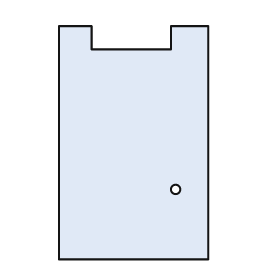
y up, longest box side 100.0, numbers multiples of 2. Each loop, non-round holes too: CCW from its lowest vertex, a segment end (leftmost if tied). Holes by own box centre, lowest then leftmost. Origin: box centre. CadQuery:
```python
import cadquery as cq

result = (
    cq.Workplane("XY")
    .moveTo(-32.0, -50.0)
    .lineTo(32.0, -50.0)
    .lineTo(32.0, 50.0)
    .lineTo(16.0, 50.0)
    .lineTo(16.0, 40.0)
    .lineTo(-18.0, 40.0)
    .lineTo(-18.0, 50.0)
    .lineTo(-32.0, 50.0)
    .close()
    .moveTo(18.0, -20.0)
    .circle(2.0)
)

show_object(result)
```